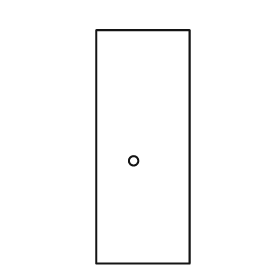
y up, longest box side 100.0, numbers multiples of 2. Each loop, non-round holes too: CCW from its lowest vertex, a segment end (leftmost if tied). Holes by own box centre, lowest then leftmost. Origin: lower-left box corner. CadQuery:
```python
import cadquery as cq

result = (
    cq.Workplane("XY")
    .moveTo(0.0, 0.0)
    .lineTo(40.0, 0.0)
    .lineTo(40.0, 100.0)
    .lineTo(0.0, 100.0)
    .close()
    .moveTo(16.0, 44.0)
    .circle(2.0)
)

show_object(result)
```